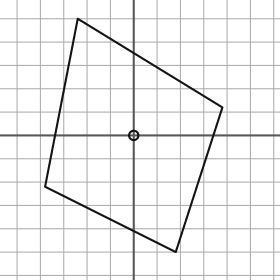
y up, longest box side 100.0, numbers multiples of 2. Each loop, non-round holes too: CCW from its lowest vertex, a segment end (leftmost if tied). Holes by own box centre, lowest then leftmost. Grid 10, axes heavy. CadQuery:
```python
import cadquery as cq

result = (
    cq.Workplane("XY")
    .moveTo(18.0, -50.0)
    .lineTo(38.0, 12.0)
    .lineTo(-24.0, 50.0)
    .lineTo(-38.0, -22.0)
    .close()
    .moveTo(0.0, 0.0)
    .circle(2.0)
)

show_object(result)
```